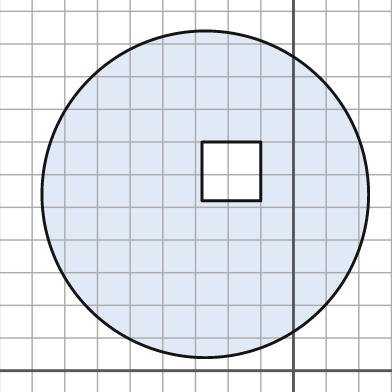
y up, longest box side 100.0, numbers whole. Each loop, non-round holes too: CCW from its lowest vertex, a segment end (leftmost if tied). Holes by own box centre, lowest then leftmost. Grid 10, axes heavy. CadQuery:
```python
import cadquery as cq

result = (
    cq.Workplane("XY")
    .moveTo(-27.0, 54.0)
    .circle(50.0)
    .moveTo(-28.0, 52.0)
    .lineTo(-10.0, 52.0)
    .lineTo(-10.0, 70.0)
    .lineTo(-28.0, 70.0)
    .close()
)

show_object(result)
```